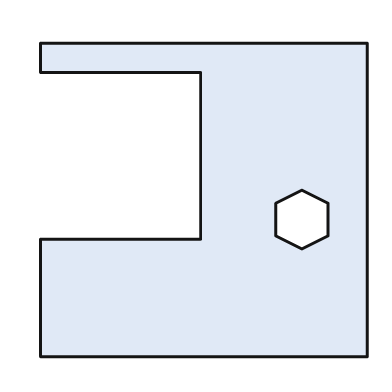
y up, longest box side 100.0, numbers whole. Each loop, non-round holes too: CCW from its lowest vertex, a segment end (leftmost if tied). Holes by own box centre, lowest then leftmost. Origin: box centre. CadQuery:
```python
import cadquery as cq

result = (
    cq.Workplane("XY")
    .moveTo(-50.0, -48.0)
    .lineTo(50.0, -48.0)
    .lineTo(50.0, 48.0)
    .lineTo(-50.0, 48.0)
    .lineTo(-50.0, 39.0)
    .lineTo(-1.0, 39.0)
    .lineTo(-1.0, -12.0)
    .lineTo(-50.0, -12.0)
    .close()
    .moveTo(30.0, -15.0)
    .lineTo(38.0, -11.0)
    .lineTo(38.0, -1.0)
    .lineTo(30.0, 3.0)
    .lineTo(22.0, -1.0)
    .lineTo(22.0, -11.0)
    .close()
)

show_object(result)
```